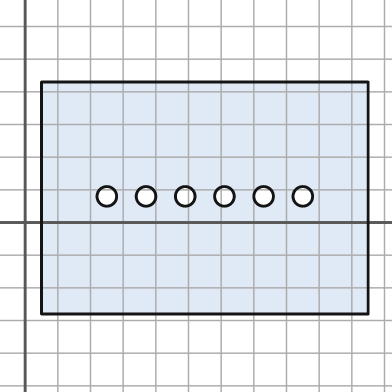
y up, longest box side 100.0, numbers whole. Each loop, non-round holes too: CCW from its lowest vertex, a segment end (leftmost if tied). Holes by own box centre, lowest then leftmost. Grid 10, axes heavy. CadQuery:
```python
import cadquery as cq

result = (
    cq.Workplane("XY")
    .moveTo(5.0, -28.0)
    .lineTo(105.0, -28.0)
    .lineTo(105.0, 43.0)
    .lineTo(5.0, 43.0)
    .close()
    .moveTo(25.0, 8.0)
    .circle(3.0)
    .moveTo(37.0, 8.0)
    .circle(3.0)
    .moveTo(49.0, 8.0)
    .circle(3.0)
    .moveTo(61.0, 8.0)
    .circle(3.0)
    .moveTo(73.0, 8.0)
    .circle(3.0)
    .moveTo(85.0, 8.0)
    .circle(3.0)
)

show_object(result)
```